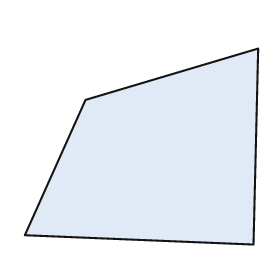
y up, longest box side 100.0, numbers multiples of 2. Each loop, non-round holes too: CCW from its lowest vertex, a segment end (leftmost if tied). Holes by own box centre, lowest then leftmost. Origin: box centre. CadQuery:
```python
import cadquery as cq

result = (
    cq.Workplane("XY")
    .moveTo(48.0, -42.0)
    .lineTo(50.0, 42.0)
    .lineTo(-24.0, 20.0)
    .lineTo(-50.0, -38.0)
    .close()
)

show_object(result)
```